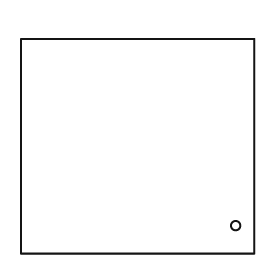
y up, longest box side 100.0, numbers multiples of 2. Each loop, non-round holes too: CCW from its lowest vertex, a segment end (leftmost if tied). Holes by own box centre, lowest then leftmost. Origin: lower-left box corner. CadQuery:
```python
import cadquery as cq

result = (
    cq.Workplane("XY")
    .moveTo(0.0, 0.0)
    .lineTo(100.0, 0.0)
    .lineTo(100.0, 92.0)
    .lineTo(0.0, 92.0)
    .close()
    .moveTo(92.0, 12.0)
    .circle(2.0)
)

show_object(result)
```